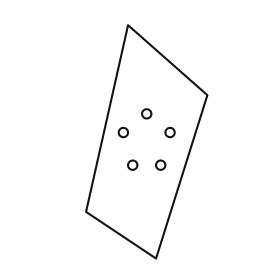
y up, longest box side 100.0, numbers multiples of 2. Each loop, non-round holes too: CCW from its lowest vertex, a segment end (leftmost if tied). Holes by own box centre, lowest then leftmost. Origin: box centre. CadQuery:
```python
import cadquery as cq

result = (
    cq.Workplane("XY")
    .moveTo(4.0, -50.0)
    .lineTo(26.0, 20.0)
    .lineTo(-8.0, 50.0)
    .lineTo(-26.0, -30.0)
    .close()
    .moveTo(-6.0, -10.0)
    .circle(2.0)
    .moveTo(6.0, -10.0)
    .circle(2.0)
    .moveTo(-10.0, 4.0)
    .circle(2.0)
    .moveTo(10.0, 4.0)
    .circle(2.0)
    .moveTo(0.0, 12.0)
    .circle(2.0)
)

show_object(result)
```